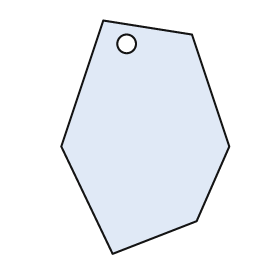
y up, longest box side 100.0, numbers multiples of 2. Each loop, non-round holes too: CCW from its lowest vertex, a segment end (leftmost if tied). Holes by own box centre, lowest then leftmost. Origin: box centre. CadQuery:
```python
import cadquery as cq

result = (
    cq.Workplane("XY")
    .moveTo(-14.0, -50.0)
    .lineTo(22.0, -36.0)
    .lineTo(36.0, -4.0)
    .lineTo(20.0, 44.0)
    .lineTo(-18.0, 50.0)
    .lineTo(-36.0, -4.0)
    .close()
    .moveTo(-8.0, 40.0)
    .circle(4.0)
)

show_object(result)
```